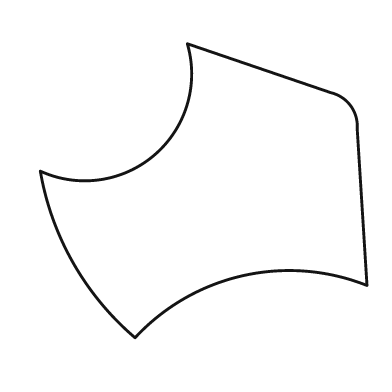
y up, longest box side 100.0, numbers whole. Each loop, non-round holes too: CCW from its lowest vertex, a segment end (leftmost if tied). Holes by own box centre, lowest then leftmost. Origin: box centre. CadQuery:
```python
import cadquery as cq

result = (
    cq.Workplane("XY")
    .moveTo(-21.0, -45.0)
    .threePointArc((12.0, -26.0), (50.0, -29.0))
    .lineTo(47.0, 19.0)
    .threePointArc((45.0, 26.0), (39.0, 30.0))
    .lineTo(-5.0, 45.0)
    .threePointArc((-15.0, 11.0), (-50.0, 6.0))
    .threePointArc((-40.0, -22.0), (-21.0, -45.0))
    .close()
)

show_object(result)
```